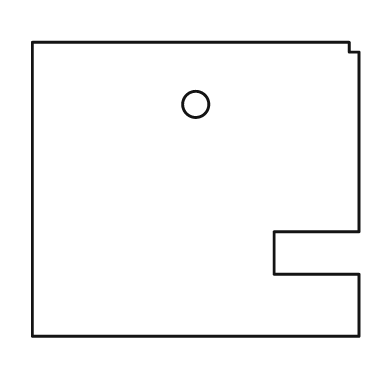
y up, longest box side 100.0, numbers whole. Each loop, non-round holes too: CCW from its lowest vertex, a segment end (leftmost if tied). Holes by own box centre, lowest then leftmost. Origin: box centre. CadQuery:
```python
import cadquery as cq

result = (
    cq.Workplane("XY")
    .moveTo(-50.0, -45.0)
    .lineTo(50.0, -45.0)
    .lineTo(50.0, -26.0)
    .lineTo(24.0, -26.0)
    .lineTo(24.0, -13.0)
    .lineTo(50.0, -13.0)
    .lineTo(50.0, 42.0)
    .lineTo(47.0, 42.0)
    .lineTo(47.0, 45.0)
    .lineTo(-50.0, 45.0)
    .close()
    .moveTo(0.0, 26.0)
    .circle(4.0)
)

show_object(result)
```